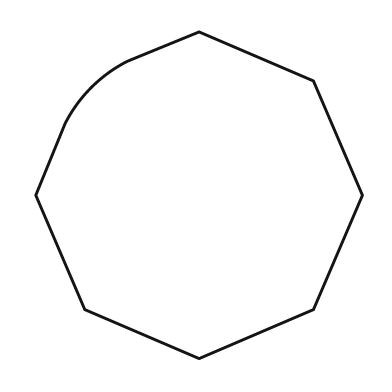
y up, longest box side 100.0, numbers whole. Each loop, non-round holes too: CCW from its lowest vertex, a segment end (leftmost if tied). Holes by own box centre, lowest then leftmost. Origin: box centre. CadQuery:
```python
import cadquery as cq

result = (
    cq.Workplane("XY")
    .moveTo(0.0, -50.0)
    .lineTo(35.0, -35.0)
    .lineTo(50.0, 0.0)
    .lineTo(35.0, 35.0)
    .lineTo(0.0, 50.0)
    .lineTo(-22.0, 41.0)
    .threePointArc((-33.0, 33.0), (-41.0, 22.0))
    .lineTo(-50.0, 0.0)
    .lineTo(-35.0, -35.0)
    .close()
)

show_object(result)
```